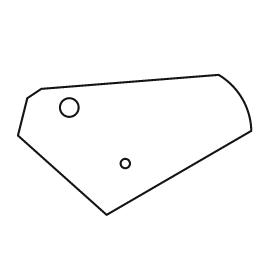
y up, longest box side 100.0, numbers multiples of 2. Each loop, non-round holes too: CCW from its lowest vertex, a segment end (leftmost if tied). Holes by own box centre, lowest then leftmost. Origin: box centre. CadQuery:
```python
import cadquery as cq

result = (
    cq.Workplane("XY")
    .moveTo(-12.0, -30.0)
    .lineTo(50.0, 6.0)
    .threePointArc((46.0, 20.0), (36.0, 30.0))
    .lineTo(-40.0, 24.0)
    .lineTo(-46.0, 20.0)
    .lineTo(-50.0, 4.0)
    .close()
    .moveTo(-4.0, -8.0)
    .circle(2.0)
    .moveTo(-28.0, 16.0)
    .circle(4.0)
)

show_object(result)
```